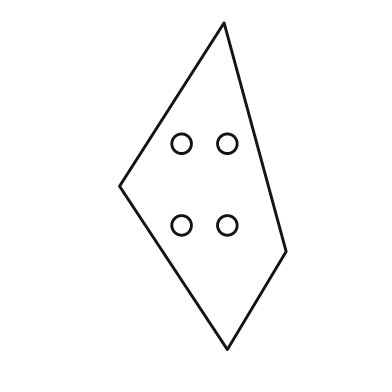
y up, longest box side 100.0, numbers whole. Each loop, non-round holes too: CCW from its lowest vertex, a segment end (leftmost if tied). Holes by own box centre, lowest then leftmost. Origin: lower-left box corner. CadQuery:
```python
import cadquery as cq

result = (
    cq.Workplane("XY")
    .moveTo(33.0, 0.0)
    .lineTo(51.0, 30.0)
    .lineTo(32.0, 100.0)
    .lineTo(0.0, 50.0)
    .close()
    .moveTo(19.0, 38.0)
    .circle(3.0)
    .moveTo(33.0, 38.0)
    .circle(3.0)
    .moveTo(19.0, 63.0)
    .circle(3.0)
    .moveTo(33.0, 63.0)
    .circle(3.0)
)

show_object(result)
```